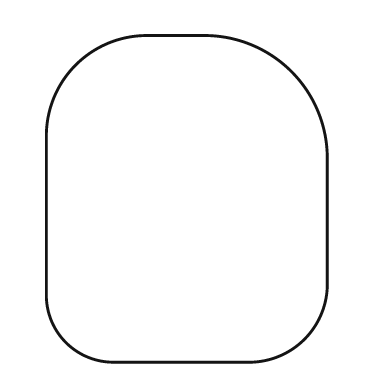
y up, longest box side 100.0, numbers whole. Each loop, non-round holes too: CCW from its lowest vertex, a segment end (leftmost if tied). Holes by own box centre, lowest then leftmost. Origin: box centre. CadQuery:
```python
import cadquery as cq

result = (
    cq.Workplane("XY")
    .moveTo(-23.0, -50.0)
    .lineTo(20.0, -50.0)
    .threePointArc((36.0, -43.0), (43.0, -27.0))
    .lineTo(43.0, 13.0)
    .threePointArc((32.0, 39.0), (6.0, 50.0))
    .lineTo(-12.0, 50.0)
    .threePointArc((-34.0, 41.0), (-43.0, 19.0))
    .lineTo(-43.0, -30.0)
    .threePointArc((-37.0, -44.0), (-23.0, -50.0))
    .close()
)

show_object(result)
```